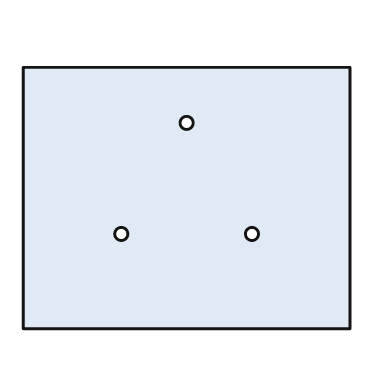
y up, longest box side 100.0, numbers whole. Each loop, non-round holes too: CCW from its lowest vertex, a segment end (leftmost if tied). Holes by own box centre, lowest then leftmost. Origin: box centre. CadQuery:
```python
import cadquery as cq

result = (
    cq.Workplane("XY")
    .moveTo(-50.0, -40.0)
    .lineTo(50.0, -40.0)
    .lineTo(50.0, 40.0)
    .lineTo(-50.0, 40.0)
    .close()
    .moveTo(-20.0, -11.0)
    .circle(2.0)
    .moveTo(20.0, -11.0)
    .circle(2.0)
    .moveTo(0.0, 23.0)
    .circle(2.0)
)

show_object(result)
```